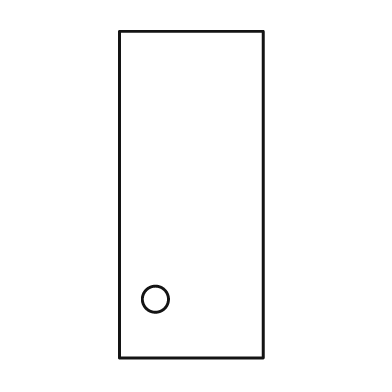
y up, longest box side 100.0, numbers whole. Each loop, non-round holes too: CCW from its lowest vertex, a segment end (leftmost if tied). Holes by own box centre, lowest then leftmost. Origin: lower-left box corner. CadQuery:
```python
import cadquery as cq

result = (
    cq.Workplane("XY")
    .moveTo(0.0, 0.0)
    .lineTo(44.0, 0.0)
    .lineTo(44.0, 100.0)
    .lineTo(0.0, 100.0)
    .close()
    .moveTo(11.0, 18.0)
    .circle(4.0)
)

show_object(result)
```